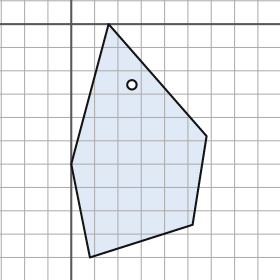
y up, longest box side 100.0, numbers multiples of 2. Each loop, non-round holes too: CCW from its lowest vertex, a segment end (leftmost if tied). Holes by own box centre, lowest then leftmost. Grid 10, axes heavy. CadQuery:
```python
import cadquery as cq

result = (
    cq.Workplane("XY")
    .moveTo(8.0, -100.0)
    .lineTo(52.0, -86.0)
    .lineTo(58.0, -48.0)
    .lineTo(16.0, 0.0)
    .lineTo(0.0, -60.0)
    .close()
    .moveTo(26.0, -26.0)
    .circle(2.0)
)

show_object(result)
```